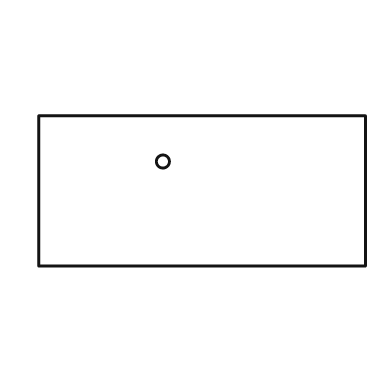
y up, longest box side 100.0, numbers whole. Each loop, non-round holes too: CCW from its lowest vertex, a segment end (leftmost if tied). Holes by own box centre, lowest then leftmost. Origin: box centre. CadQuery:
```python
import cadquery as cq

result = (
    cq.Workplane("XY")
    .moveTo(-50.0, -23.0)
    .lineTo(50.0, -23.0)
    .lineTo(50.0, 23.0)
    .lineTo(-50.0, 23.0)
    .close()
    .moveTo(-12.0, 9.0)
    .circle(2.0)
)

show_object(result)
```